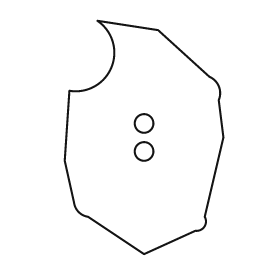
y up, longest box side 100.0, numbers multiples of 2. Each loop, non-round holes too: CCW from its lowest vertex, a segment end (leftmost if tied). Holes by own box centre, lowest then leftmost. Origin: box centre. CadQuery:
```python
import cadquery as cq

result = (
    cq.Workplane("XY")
    .moveTo(0.0, -50.0)
    .lineTo(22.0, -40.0)
    .threePointArc((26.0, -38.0), (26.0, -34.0))
    .lineTo(34.0, 0.0)
    .lineTo(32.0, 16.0)
    .threePointArc((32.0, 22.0), (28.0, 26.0))
    .lineTo(6.0, 46.0)
    .lineTo(-20.0, 50.0)
    .threePointArc((-14.0, 30.0), (-32.0, 20.0))
    .lineTo(-34.0, -10.0)
    .lineTo(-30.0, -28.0)
    .threePointArc((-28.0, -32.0), (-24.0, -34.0))
    .close()
    .moveTo(0.0, -6.0)
    .circle(4.0)
    .moveTo(0.0, 6.0)
    .circle(4.0)
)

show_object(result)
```